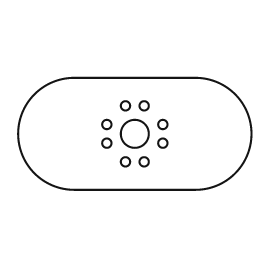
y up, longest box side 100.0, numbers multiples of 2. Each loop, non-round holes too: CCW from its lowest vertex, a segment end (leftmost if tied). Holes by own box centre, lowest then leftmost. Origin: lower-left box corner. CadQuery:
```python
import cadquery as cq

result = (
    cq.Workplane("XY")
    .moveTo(24.0, 0.0)
    .lineTo(76.0, 0.0)
    .threePointArc((100.0, 24.0), (76.0, 48.0))
    .lineTo(24.0, 48.0)
    .threePointArc((0.0, 24.0), (24.0, 0.0))
    .close()
    .moveTo(46.0, 12.0)
    .circle(2.0)
    .moveTo(54.0, 12.0)
    .circle(2.0)
    .moveTo(38.0, 20.0)
    .circle(2.0)
    .moveTo(62.0, 20.0)
    .circle(2.0)
    .moveTo(50.0, 24.0)
    .circle(6.0)
    .moveTo(38.0, 28.0)
    .circle(2.0)
    .moveTo(62.0, 28.0)
    .circle(2.0)
    .moveTo(46.0, 36.0)
    .circle(2.0)
    .moveTo(54.0, 36.0)
    .circle(2.0)
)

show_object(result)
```